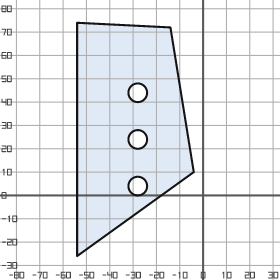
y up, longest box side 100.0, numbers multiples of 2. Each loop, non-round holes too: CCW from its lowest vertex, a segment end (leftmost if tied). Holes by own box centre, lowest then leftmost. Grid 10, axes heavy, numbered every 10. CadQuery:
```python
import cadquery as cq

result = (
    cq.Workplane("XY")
    .moveTo(-54.0, -26.0)
    .lineTo(-4.0, 10.0)
    .lineTo(-14.0, 72.0)
    .lineTo(-54.0, 74.0)
    .close()
    .moveTo(-28.0, 4.0)
    .circle(4.0)
    .moveTo(-28.0, 24.0)
    .circle(4.0)
    .moveTo(-28.0, 44.0)
    .circle(4.0)
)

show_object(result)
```